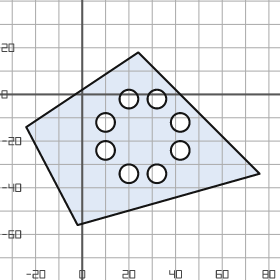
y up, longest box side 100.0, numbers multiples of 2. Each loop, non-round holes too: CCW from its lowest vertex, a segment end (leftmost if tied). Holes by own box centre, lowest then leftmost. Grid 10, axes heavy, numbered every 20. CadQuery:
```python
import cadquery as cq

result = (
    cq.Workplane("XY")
    .moveTo(-2.0, -56.0)
    .lineTo(76.0, -34.0)
    .lineTo(24.0, 18.0)
    .lineTo(-24.0, -14.0)
    .close()
    .moveTo(20.0, -34.0)
    .circle(4.0)
    .moveTo(32.0, -34.0)
    .circle(4.0)
    .moveTo(10.0, -24.0)
    .circle(4.0)
    .moveTo(42.0, -24.0)
    .circle(4.0)
    .moveTo(10.0, -12.0)
    .circle(4.0)
    .moveTo(42.0, -12.0)
    .circle(4.0)
    .moveTo(20.0, -2.0)
    .circle(4.0)
    .moveTo(32.0, -2.0)
    .circle(4.0)
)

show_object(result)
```